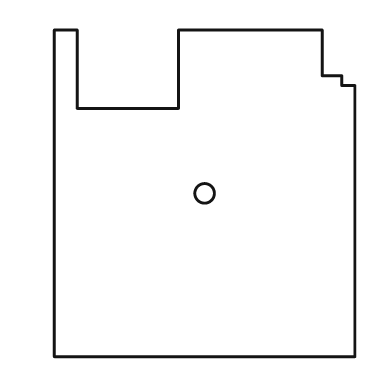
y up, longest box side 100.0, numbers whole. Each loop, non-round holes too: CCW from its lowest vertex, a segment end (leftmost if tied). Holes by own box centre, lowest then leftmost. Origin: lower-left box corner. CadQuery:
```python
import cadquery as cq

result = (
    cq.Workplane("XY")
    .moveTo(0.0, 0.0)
    .lineTo(92.0, 0.0)
    .lineTo(92.0, 83.0)
    .lineTo(88.0, 83.0)
    .lineTo(88.0, 86.0)
    .lineTo(82.0, 86.0)
    .lineTo(82.0, 100.0)
    .lineTo(38.0, 100.0)
    .lineTo(38.0, 76.0)
    .lineTo(7.0, 76.0)
    .lineTo(7.0, 100.0)
    .lineTo(0.0, 100.0)
    .close()
    .moveTo(46.0, 50.0)
    .circle(3.0)
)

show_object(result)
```